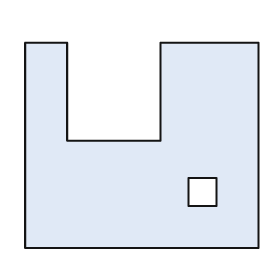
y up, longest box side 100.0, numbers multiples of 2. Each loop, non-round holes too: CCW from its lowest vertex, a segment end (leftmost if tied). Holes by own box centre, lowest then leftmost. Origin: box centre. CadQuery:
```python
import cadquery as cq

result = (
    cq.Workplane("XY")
    .moveTo(-50.0, -44.0)
    .lineTo(50.0, -44.0)
    .lineTo(50.0, 44.0)
    .lineTo(8.0, 44.0)
    .lineTo(8.0, 2.0)
    .lineTo(-32.0, 2.0)
    .lineTo(-32.0, 44.0)
    .lineTo(-50.0, 44.0)
    .close()
    .moveTo(20.0, -26.0)
    .lineTo(32.0, -26.0)
    .lineTo(32.0, -14.0)
    .lineTo(20.0, -14.0)
    .close()
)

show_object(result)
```